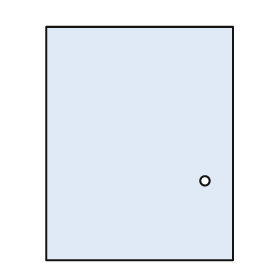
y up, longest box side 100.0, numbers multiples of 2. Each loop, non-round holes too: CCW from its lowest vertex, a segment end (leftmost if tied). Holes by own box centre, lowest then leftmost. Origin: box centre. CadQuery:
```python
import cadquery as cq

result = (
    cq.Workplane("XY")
    .moveTo(-40.0, -50.0)
    .lineTo(40.0, -50.0)
    .lineTo(40.0, 50.0)
    .lineTo(-40.0, 50.0)
    .close()
    .moveTo(28.0, -16.0)
    .circle(2.0)
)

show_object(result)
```